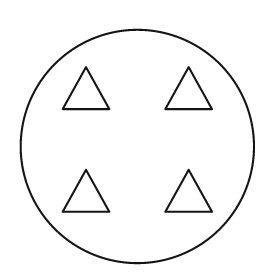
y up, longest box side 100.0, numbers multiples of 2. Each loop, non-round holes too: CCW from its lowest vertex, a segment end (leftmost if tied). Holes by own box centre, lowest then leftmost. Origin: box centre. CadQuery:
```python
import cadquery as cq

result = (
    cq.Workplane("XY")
    .moveTo(0.0, 0.0)
    .circle(50.0)
    .moveTo(-32.0, -28.0)
    .lineTo(-12.0, -28.0)
    .lineTo(-22.0, -10.0)
    .close()
    .moveTo(12.0, -28.0)
    .lineTo(32.0, -28.0)
    .lineTo(22.0, -10.0)
    .close()
    .moveTo(-32.0, 16.0)
    .lineTo(-12.0, 16.0)
    .lineTo(-22.0, 34.0)
    .close()
    .moveTo(12.0, 16.0)
    .lineTo(32.0, 16.0)
    .lineTo(22.0, 34.0)
    .close()
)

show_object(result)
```